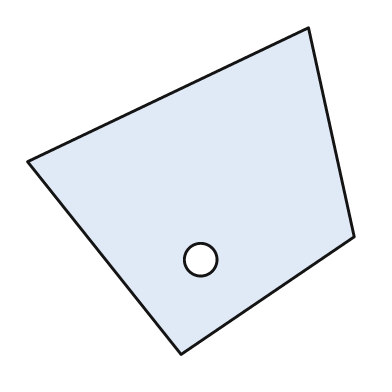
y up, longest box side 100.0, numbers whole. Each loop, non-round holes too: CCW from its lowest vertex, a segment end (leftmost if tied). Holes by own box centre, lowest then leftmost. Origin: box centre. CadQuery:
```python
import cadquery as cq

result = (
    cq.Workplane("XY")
    .moveTo(-3.0, -50.0)
    .lineTo(50.0, -14.0)
    .lineTo(36.0, 50.0)
    .lineTo(-50.0, 9.0)
    .close()
    .moveTo(3.0, -21.0)
    .circle(5.0)
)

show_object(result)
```